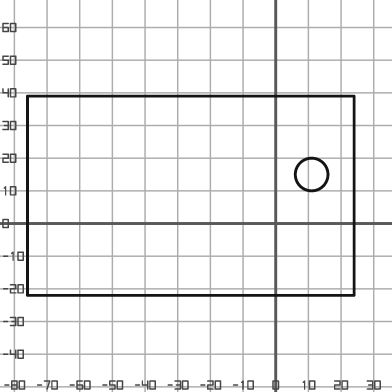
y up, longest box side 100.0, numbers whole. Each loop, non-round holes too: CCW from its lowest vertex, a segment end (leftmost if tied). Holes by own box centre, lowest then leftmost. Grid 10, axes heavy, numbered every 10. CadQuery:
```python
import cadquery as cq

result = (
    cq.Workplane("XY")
    .moveTo(-76.0, -22.0)
    .lineTo(24.0, -22.0)
    .lineTo(24.0, 39.0)
    .lineTo(-76.0, 39.0)
    .close()
    .moveTo(11.0, 15.0)
    .circle(5.0)
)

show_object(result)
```